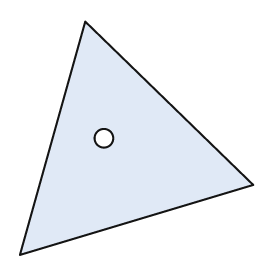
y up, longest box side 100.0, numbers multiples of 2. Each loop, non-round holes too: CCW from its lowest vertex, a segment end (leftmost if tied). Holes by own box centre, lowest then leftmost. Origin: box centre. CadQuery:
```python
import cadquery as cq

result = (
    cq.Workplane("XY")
    .moveTo(-50.0, -50.0)
    .lineTo(50.0, -20.0)
    .lineTo(-22.0, 50.0)
    .close()
    .moveTo(-14.0, 0.0)
    .circle(4.0)
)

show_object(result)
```